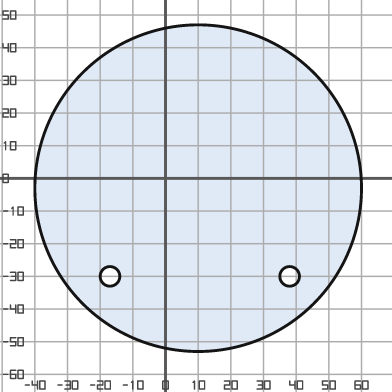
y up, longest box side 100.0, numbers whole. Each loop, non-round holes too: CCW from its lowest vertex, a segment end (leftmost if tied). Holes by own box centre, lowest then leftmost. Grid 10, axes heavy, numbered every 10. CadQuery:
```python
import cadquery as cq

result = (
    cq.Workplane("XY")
    .moveTo(10.0, -3.0)
    .circle(50.0)
    .moveTo(-17.0, -30.0)
    .circle(3.0)
    .moveTo(38.0, -30.0)
    .circle(3.0)
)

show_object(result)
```